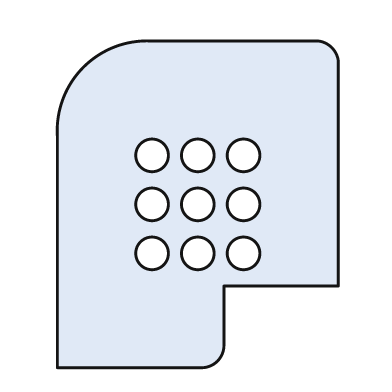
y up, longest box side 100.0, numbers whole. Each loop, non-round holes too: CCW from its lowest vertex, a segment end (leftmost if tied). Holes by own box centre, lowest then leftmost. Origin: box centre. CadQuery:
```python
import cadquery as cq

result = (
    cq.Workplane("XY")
    .moveTo(-43.0, -50.0)
    .lineTo(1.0, -50.0)
    .threePointArc((6.0, -48.0), (8.0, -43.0))
    .lineTo(8.0, -25.0)
    .lineTo(43.0, -25.0)
    .lineTo(43.0, 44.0)
    .threePointArc((41.0, 48.0), (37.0, 50.0))
    .lineTo(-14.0, 50.0)
    .threePointArc((-35.0, 42.0), (-43.0, 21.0))
    .close()
    .moveTo(-14.0, -15.0)
    .circle(5.0)
    .moveTo(0.0, -15.0)
    .circle(5.0)
    .moveTo(14.0, -15.0)
    .circle(5.0)
    .moveTo(-14.0, 0.0)
    .circle(5.0)
    .moveTo(0.0, 0.0)
    .circle(5.0)
    .moveTo(14.0, 0.0)
    .circle(5.0)
    .moveTo(-14.0, 15.0)
    .circle(5.0)
    .moveTo(0.0, 15.0)
    .circle(5.0)
    .moveTo(14.0, 15.0)
    .circle(5.0)
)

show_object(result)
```